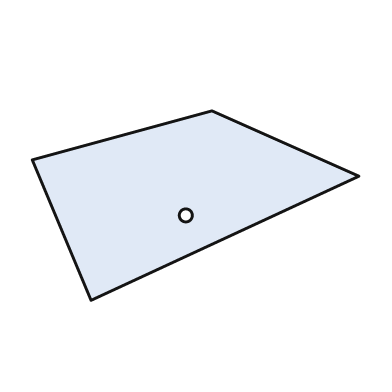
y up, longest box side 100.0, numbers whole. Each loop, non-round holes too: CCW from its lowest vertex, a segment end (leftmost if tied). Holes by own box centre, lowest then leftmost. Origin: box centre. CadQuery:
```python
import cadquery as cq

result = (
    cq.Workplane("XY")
    .moveTo(-32.0, -29.0)
    .lineTo(50.0, 9.0)
    .lineTo(5.0, 29.0)
    .lineTo(-50.0, 14.0)
    .close()
    .moveTo(-3.0, -3.0)
    .circle(2.0)
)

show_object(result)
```